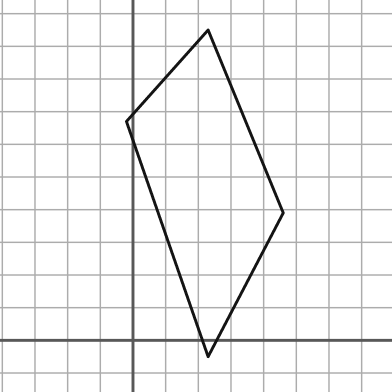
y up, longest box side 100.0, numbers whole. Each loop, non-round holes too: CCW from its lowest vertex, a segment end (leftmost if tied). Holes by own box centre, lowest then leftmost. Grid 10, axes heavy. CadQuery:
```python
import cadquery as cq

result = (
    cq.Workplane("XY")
    .moveTo(23.0, -5.0)
    .lineTo(46.0, 39.0)
    .lineTo(23.0, 95.0)
    .lineTo(-2.0, 67.0)
    .close()
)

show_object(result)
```